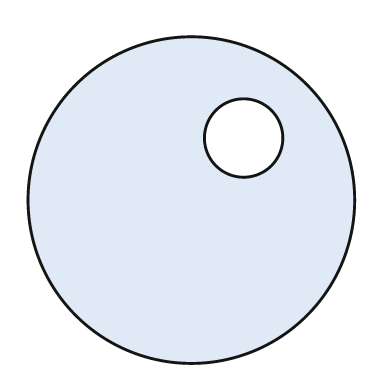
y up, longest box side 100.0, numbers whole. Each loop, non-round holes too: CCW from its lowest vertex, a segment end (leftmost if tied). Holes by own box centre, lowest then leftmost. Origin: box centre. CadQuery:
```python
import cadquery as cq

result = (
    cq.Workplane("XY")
    .moveTo(0.0, 0.0)
    .circle(50.0)
    .moveTo(16.0, 19.0)
    .circle(12.0)
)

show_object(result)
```